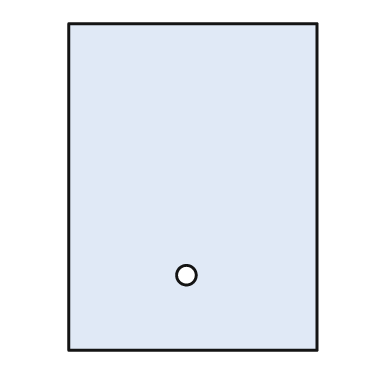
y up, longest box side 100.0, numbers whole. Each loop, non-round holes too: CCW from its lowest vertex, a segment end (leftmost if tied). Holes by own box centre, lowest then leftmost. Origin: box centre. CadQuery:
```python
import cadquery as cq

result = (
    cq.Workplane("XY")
    .moveTo(-38.0, -50.0)
    .lineTo(38.0, -50.0)
    .lineTo(38.0, 50.0)
    .lineTo(-38.0, 50.0)
    .close()
    .moveTo(-2.0, -27.0)
    .circle(3.0)
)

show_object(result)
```